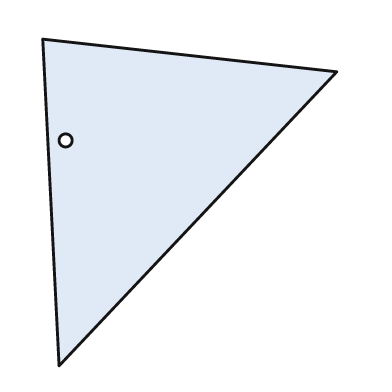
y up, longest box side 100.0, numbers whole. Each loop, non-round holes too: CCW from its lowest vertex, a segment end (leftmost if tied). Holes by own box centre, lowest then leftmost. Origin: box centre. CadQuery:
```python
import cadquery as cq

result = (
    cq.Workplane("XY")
    .moveTo(-40.0, -50.0)
    .lineTo(45.0, 40.0)
    .lineTo(-45.0, 50.0)
    .close()
    .moveTo(-38.0, 19.0)
    .circle(2.0)
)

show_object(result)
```